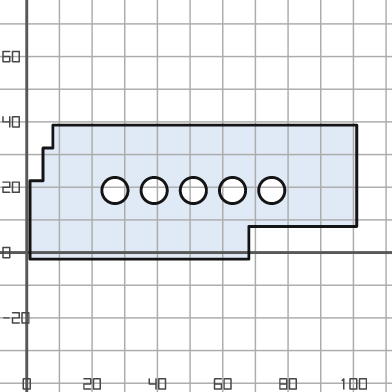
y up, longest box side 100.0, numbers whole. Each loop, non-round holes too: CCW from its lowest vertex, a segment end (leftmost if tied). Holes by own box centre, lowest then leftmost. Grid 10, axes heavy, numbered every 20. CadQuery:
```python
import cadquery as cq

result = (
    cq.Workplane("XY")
    .moveTo(1.0, -2.0)
    .lineTo(68.0, -2.0)
    .lineTo(68.0, 8.0)
    .lineTo(101.0, 8.0)
    .lineTo(101.0, 39.0)
    .lineTo(8.0, 39.0)
    .lineTo(8.0, 32.0)
    .lineTo(5.0, 32.0)
    .lineTo(5.0, 22.0)
    .lineTo(1.0, 22.0)
    .close()
    .moveTo(27.0, 19.0)
    .circle(4.0)
    .moveTo(39.0, 19.0)
    .circle(4.0)
    .moveTo(51.0, 19.0)
    .circle(4.0)
    .moveTo(63.0, 19.0)
    .circle(4.0)
    .moveTo(75.0, 19.0)
    .circle(4.0)
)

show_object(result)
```